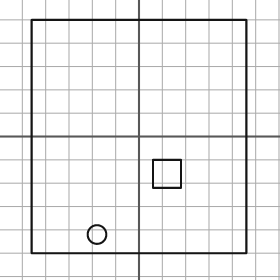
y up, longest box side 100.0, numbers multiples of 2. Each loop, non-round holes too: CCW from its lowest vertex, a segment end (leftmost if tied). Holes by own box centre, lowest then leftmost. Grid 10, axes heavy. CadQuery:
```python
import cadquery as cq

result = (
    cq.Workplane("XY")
    .moveTo(-46.0, -50.0)
    .lineTo(46.0, -50.0)
    .lineTo(46.0, 50.0)
    .lineTo(-46.0, 50.0)
    .close()
    .moveTo(-18.0, -42.0)
    .circle(4.0)
    .moveTo(6.0, -22.0)
    .lineTo(18.0, -22.0)
    .lineTo(18.0, -10.0)
    .lineTo(6.0, -10.0)
    .close()
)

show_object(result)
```